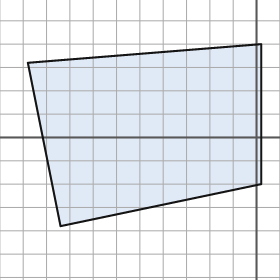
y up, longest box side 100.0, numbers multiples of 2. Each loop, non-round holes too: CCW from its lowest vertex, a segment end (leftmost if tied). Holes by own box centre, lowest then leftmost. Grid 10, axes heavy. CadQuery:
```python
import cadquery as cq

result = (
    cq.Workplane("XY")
    .moveTo(-84.0, -38.0)
    .lineTo(2.0, -20.0)
    .lineTo(2.0, 40.0)
    .lineTo(-98.0, 32.0)
    .close()
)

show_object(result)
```